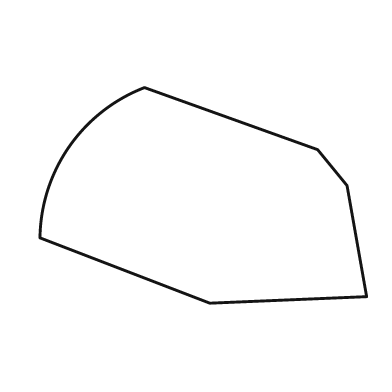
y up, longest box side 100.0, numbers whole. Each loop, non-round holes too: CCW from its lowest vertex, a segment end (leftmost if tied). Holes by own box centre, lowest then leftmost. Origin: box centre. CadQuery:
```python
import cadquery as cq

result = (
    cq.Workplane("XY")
    .moveTo(2.0, -33.0)
    .lineTo(50.0, -31.0)
    .lineTo(44.0, 3.0)
    .lineTo(35.0, 14.0)
    .lineTo(-18.0, 33.0)
    .threePointArc((-41.0, 15.0), (-50.0, -13.0))
    .close()
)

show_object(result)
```